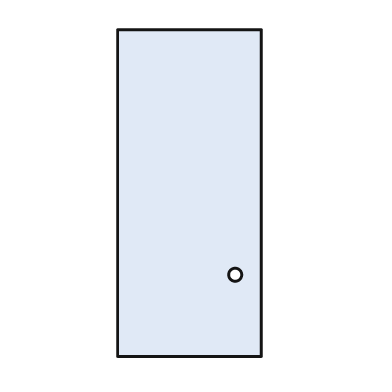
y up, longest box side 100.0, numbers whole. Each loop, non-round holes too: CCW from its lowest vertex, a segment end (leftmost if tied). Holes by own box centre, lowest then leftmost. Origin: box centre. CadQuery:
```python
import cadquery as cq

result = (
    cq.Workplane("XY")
    .moveTo(-22.0, -50.0)
    .lineTo(22.0, -50.0)
    .lineTo(22.0, 50.0)
    .lineTo(-22.0, 50.0)
    .close()
    .moveTo(14.0, -25.0)
    .circle(2.0)
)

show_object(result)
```